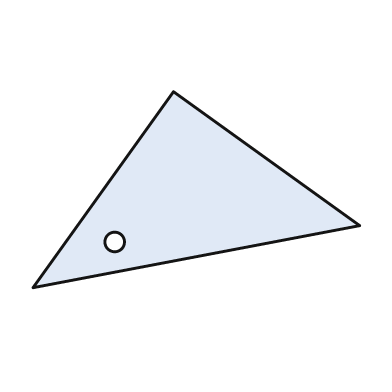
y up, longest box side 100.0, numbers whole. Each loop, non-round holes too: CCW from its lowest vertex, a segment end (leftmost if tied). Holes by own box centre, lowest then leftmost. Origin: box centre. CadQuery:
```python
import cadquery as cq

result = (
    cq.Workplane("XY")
    .moveTo(-50.0, -30.0)
    .lineTo(50.0, -11.0)
    .lineTo(-7.0, 30.0)
    .close()
    .moveTo(-25.0, -16.0)
    .circle(3.0)
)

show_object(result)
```